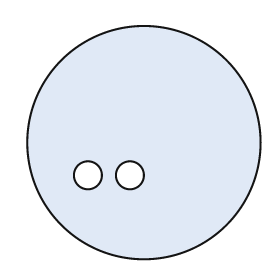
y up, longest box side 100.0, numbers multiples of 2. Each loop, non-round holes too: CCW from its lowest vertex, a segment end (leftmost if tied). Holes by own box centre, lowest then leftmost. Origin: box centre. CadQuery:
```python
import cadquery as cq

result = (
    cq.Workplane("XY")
    .moveTo(0.0, 0.0)
    .circle(50.0)
    .moveTo(-24.0, -14.0)
    .circle(6.0)
    .moveTo(-6.0, -14.0)
    .circle(6.0)
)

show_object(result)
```